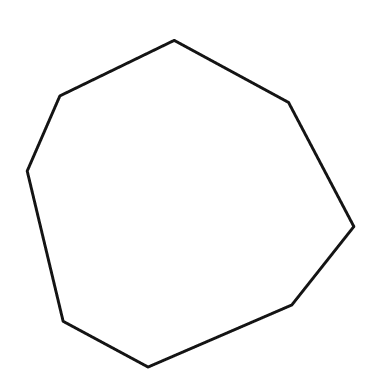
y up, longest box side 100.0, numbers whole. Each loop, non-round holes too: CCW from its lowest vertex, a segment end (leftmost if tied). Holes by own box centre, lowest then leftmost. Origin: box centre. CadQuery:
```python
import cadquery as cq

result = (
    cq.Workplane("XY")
    .moveTo(-13.0, -50.0)
    .lineTo(31.0, -31.0)
    .lineTo(50.0, -7.0)
    .lineTo(30.0, 31.0)
    .lineTo(-5.0, 50.0)
    .lineTo(-40.0, 33.0)
    .lineTo(-50.0, 10.0)
    .lineTo(-39.0, -36.0)
    .close()
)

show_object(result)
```